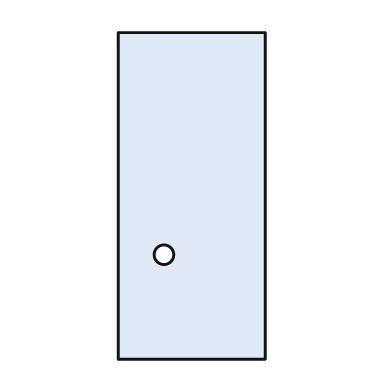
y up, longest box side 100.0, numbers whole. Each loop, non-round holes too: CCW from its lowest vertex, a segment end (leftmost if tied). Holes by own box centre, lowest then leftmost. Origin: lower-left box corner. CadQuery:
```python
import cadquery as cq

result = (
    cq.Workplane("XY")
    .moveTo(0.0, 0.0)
    .lineTo(45.0, 0.0)
    .lineTo(45.0, 100.0)
    .lineTo(0.0, 100.0)
    .close()
    .moveTo(14.0, 32.0)
    .circle(3.0)
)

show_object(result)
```